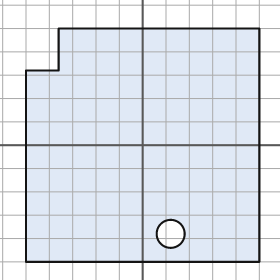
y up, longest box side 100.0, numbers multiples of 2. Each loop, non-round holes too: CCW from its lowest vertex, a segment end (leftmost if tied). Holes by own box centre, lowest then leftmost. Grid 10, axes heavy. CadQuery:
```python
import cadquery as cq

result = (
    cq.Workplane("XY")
    .moveTo(-50.0, -50.0)
    .lineTo(50.0, -50.0)
    .lineTo(50.0, 50.0)
    .lineTo(-36.0, 50.0)
    .lineTo(-36.0, 32.0)
    .lineTo(-50.0, 32.0)
    .close()
    .moveTo(12.0, -38.0)
    .circle(6.0)
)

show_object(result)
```